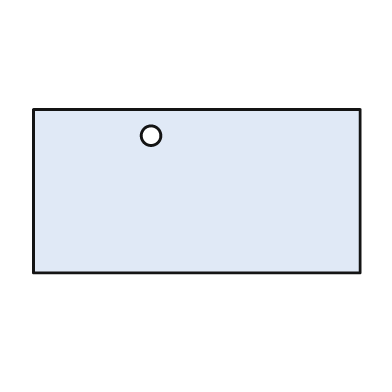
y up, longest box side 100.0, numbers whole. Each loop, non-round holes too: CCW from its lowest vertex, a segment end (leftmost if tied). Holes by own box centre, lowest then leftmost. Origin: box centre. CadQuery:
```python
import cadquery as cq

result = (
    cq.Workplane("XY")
    .moveTo(-50.0, -25.0)
    .lineTo(50.0, -25.0)
    .lineTo(50.0, 25.0)
    .lineTo(-50.0, 25.0)
    .close()
    .moveTo(-14.0, 17.0)
    .circle(3.0)
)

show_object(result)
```